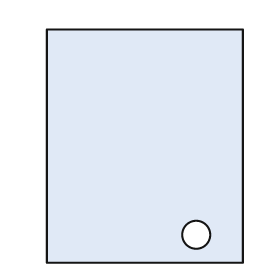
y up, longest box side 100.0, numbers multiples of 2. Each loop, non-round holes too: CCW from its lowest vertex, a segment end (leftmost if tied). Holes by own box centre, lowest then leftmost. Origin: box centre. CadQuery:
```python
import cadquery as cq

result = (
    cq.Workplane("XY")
    .moveTo(-42.0, -50.0)
    .lineTo(42.0, -50.0)
    .lineTo(42.0, 50.0)
    .lineTo(-42.0, 50.0)
    .close()
    .moveTo(22.0, -38.0)
    .circle(6.0)
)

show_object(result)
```